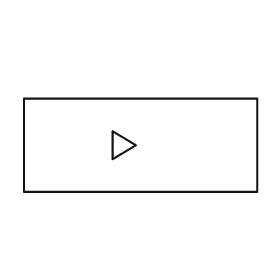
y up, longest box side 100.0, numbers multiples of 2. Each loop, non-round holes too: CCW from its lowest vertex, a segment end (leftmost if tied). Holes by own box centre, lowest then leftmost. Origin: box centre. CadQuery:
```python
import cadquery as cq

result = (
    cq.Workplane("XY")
    .moveTo(-50.0, -20.0)
    .lineTo(50.0, -20.0)
    .lineTo(50.0, 20.0)
    .lineTo(-50.0, 20.0)
    .close()
    .moveTo(-12.0, -6.0)
    .lineTo(-2.0, 0.0)
    .lineTo(-12.0, 6.0)
    .close()
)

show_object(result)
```